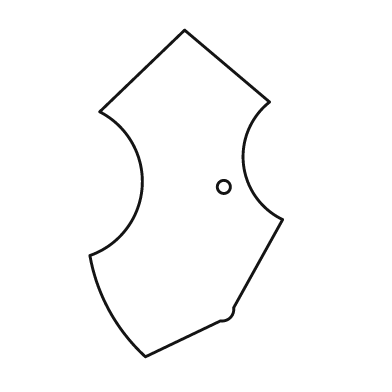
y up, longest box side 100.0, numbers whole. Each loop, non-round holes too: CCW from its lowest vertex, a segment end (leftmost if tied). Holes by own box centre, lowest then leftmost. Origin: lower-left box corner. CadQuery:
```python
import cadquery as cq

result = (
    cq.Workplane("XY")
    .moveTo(17.0, 0.0)
    .lineTo(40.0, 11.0)
    .threePointArc((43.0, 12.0), (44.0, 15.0))
    .lineTo(59.0, 42.0)
    .threePointArc((47.0, 59.0), (55.0, 78.0))
    .lineTo(29.0, 100.0)
    .lineTo(3.0, 75.0)
    .threePointArc((16.0, 52.0), (0.0, 31.0))
    .threePointArc((6.0, 14.0), (17.0, 0.0))
    .close()
    .moveTo(41.0, 52.0)
    .circle(2.0)
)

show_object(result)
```